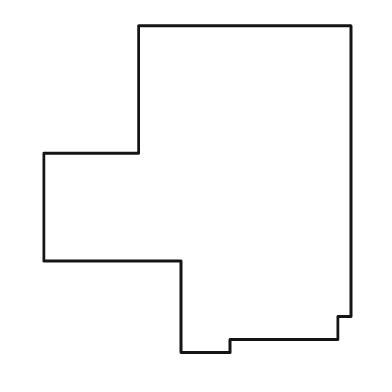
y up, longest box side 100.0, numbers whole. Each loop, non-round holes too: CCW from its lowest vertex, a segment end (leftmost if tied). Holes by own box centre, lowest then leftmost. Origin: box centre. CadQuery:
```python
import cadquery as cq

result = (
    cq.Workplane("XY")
    .moveTo(-5.0, -50.0)
    .lineTo(10.0, -50.0)
    .lineTo(10.0, -46.0)
    .lineTo(43.0, -46.0)
    .lineTo(43.0, -39.0)
    .lineTo(47.0, -39.0)
    .lineTo(47.0, 50.0)
    .lineTo(-18.0, 50.0)
    .lineTo(-18.0, 11.0)
    .lineTo(-47.0, 11.0)
    .lineTo(-47.0, -22.0)
    .lineTo(-5.0, -22.0)
    .close()
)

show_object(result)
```